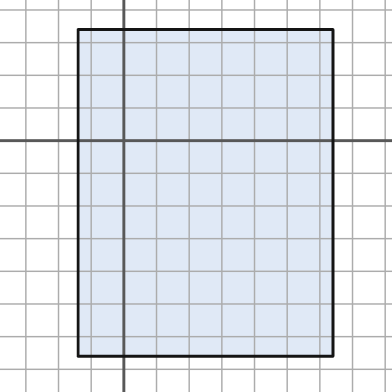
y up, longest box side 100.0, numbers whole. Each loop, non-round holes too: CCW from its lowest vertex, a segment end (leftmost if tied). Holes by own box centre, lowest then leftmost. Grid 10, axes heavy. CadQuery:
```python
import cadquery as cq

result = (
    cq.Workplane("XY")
    .moveTo(-14.0, -66.0)
    .lineTo(64.0, -66.0)
    .lineTo(64.0, 34.0)
    .lineTo(-14.0, 34.0)
    .close()
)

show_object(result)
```